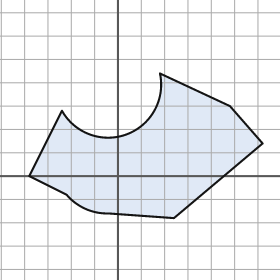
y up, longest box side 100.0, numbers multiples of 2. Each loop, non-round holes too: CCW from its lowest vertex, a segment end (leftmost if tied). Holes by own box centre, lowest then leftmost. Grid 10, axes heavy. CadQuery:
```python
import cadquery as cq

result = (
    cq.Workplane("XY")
    .moveTo(24.0, -18.0)
    .lineTo(62.0, 14.0)
    .lineTo(48.0, 30.0)
    .lineTo(18.0, 44.0)
    .threePointArc((4.0, 18.0), (-24.0, 28.0))
    .lineTo(-38.0, 0.0)
    .lineTo(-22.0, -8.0)
    .threePointArc((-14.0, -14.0), (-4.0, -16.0))
    .close()
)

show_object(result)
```